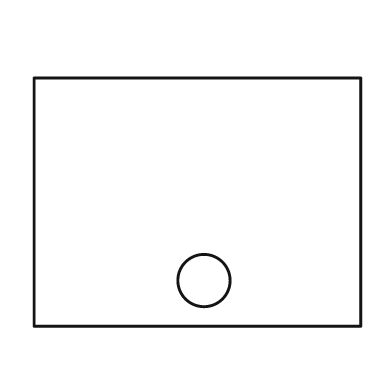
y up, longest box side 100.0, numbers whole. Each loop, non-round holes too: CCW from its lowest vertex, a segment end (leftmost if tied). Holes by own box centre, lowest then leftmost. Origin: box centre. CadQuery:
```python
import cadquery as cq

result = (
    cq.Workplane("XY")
    .moveTo(-50.0, -38.0)
    .lineTo(50.0, -38.0)
    .lineTo(50.0, 38.0)
    .lineTo(-50.0, 38.0)
    .close()
    .moveTo(2.0, -24.0)
    .circle(8.0)
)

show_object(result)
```